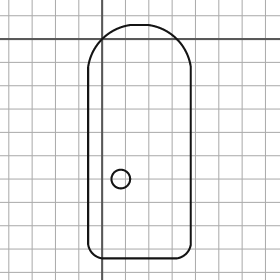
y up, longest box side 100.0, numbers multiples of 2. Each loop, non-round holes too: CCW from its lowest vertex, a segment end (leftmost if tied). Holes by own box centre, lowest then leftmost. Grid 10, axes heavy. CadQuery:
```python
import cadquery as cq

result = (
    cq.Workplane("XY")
    .moveTo(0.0, -94.0)
    .lineTo(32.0, -94.0)
    .threePointArc((36.0, -92.0), (38.0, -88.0))
    .lineTo(38.0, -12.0)
    .threePointArc((32.0, 0.0), (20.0, 6.0))
    .lineTo(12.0, 6.0)
    .threePointArc((0.0, 0.0), (-6.0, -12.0))
    .lineTo(-6.0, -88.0)
    .threePointArc((-4.0, -92.0), (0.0, -94.0))
    .close()
    .moveTo(8.0, -60.0)
    .circle(4.0)
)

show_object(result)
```